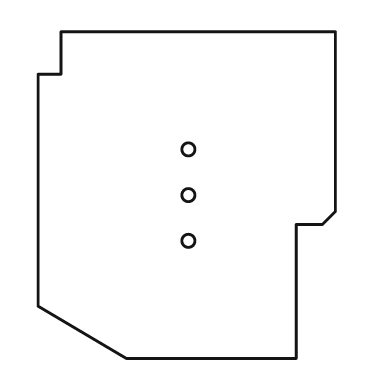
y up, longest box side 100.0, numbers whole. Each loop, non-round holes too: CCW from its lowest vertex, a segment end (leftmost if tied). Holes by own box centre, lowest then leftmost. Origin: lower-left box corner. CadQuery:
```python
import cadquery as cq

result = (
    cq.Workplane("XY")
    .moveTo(27.0, 0.0)
    .lineTo(79.0, 0.0)
    .lineTo(79.0, 41.0)
    .lineTo(87.0, 41.0)
    .lineTo(91.0, 45.0)
    .lineTo(91.0, 100.0)
    .lineTo(7.0, 100.0)
    .lineTo(7.0, 87.0)
    .lineTo(0.0, 87.0)
    .lineTo(0.0, 16.0)
    .close()
    .moveTo(46.0, 36.0)
    .circle(2.0)
    .moveTo(46.0, 50.0)
    .circle(2.0)
    .moveTo(46.0, 64.0)
    .circle(2.0)
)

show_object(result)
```